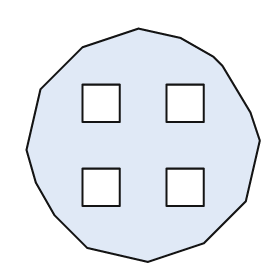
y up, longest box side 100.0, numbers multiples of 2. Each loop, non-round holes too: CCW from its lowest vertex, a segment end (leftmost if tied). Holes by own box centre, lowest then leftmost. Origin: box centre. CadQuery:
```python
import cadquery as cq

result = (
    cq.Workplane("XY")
    .moveTo(2.0, -50.0)
    .lineTo(26.0, -42.0)
    .lineTo(44.0, -24.0)
    .lineTo(50.0, 2.0)
    .lineTo(46.0, 14.0)
    .lineTo(34.0, 34.0)
    .lineTo(30.0, 38.0)
    .lineTo(16.0, 46.0)
    .lineTo(-2.0, 50.0)
    .lineTo(-26.0, 42.0)
    .lineTo(-44.0, 24.0)
    .lineTo(-50.0, -2.0)
    .lineTo(-46.0, -16.0)
    .lineTo(-38.0, -30.0)
    .lineTo(-24.0, -44.0)
    .close()
    .moveTo(-26.0, -26.0)
    .lineTo(-10.0, -26.0)
    .lineTo(-10.0, -10.0)
    .lineTo(-26.0, -10.0)
    .close()
    .moveTo(10.0, -26.0)
    .lineTo(26.0, -26.0)
    .lineTo(26.0, -10.0)
    .lineTo(10.0, -10.0)
    .close()
    .moveTo(-26.0, 10.0)
    .lineTo(-10.0, 10.0)
    .lineTo(-10.0, 26.0)
    .lineTo(-26.0, 26.0)
    .close()
    .moveTo(10.0, 10.0)
    .lineTo(26.0, 10.0)
    .lineTo(26.0, 26.0)
    .lineTo(10.0, 26.0)
    .close()
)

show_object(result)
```